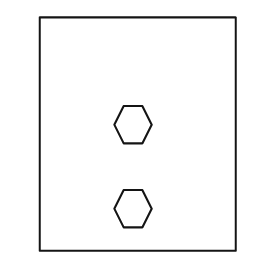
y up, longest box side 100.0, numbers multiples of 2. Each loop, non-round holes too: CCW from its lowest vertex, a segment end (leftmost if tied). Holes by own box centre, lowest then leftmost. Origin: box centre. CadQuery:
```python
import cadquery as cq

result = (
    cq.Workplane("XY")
    .moveTo(-42.0, -50.0)
    .lineTo(42.0, -50.0)
    .lineTo(42.0, 50.0)
    .lineTo(-42.0, 50.0)
    .close()
    .moveTo(-6.0, -40.0)
    .lineTo(2.0, -40.0)
    .lineTo(6.0, -32.0)
    .lineTo(2.0, -24.0)
    .lineTo(-6.0, -24.0)
    .lineTo(-10.0, -32.0)
    .close()
    .moveTo(-6.0, -4.0)
    .lineTo(2.0, -4.0)
    .lineTo(6.0, 4.0)
    .lineTo(2.0, 12.0)
    .lineTo(-6.0, 12.0)
    .lineTo(-10.0, 4.0)
    .close()
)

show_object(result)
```